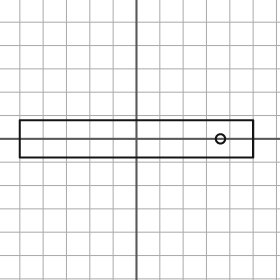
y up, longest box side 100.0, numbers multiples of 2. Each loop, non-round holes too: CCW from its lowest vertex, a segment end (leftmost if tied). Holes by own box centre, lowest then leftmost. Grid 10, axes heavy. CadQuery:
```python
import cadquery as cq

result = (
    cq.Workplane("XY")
    .moveTo(-50.0, -8.0)
    .lineTo(50.0, -8.0)
    .lineTo(50.0, 8.0)
    .lineTo(-50.0, 8.0)
    .close()
    .moveTo(36.0, 0.0)
    .circle(2.0)
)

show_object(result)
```